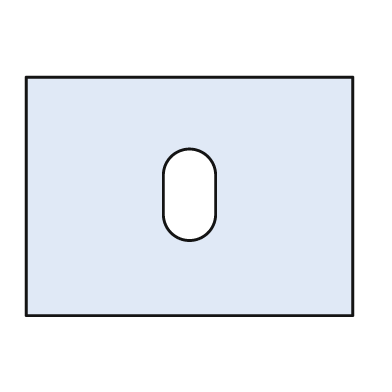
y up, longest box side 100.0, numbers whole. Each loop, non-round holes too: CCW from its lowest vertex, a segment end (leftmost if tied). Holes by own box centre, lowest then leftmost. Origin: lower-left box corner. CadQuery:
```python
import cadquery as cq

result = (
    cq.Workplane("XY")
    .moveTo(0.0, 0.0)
    .lineTo(100.0, 0.0)
    .lineTo(100.0, 73.0)
    .lineTo(0.0, 73.0)
    .close()
    .moveTo(42.0, 31.0)
    .threePointArc((50.0, 23.0), (58.0, 31.0))
    .lineTo(58.0, 43.0)
    .threePointArc((50.0, 51.0), (42.0, 43.0))
    .close()
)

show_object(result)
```